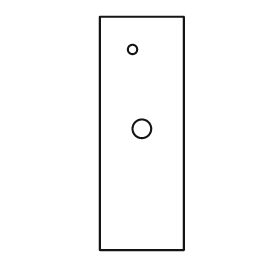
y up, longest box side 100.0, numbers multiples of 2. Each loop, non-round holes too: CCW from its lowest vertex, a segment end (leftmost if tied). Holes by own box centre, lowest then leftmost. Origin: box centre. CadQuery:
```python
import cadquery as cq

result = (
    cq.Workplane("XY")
    .moveTo(-18.0, -50.0)
    .lineTo(18.0, -50.0)
    .lineTo(18.0, 50.0)
    .lineTo(-18.0, 50.0)
    .close()
    .moveTo(0.0, 2.0)
    .circle(4.0)
    .moveTo(-4.0, 36.0)
    .circle(2.0)
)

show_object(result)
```